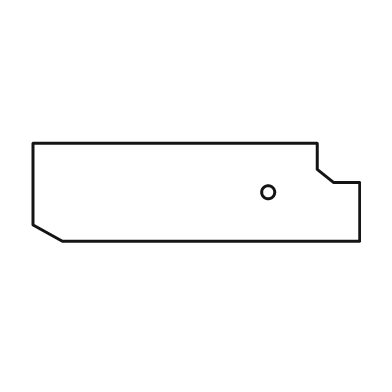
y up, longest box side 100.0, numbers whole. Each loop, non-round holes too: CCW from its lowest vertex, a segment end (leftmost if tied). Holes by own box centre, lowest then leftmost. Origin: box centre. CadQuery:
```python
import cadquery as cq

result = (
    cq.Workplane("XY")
    .moveTo(-41.0, -15.0)
    .lineTo(50.0, -15.0)
    .lineTo(50.0, 3.0)
    .lineTo(42.0, 3.0)
    .lineTo(37.0, 7.0)
    .lineTo(37.0, 15.0)
    .lineTo(-50.0, 15.0)
    .lineTo(-50.0, -10.0)
    .close()
    .moveTo(22.0, 0.0)
    .circle(2.0)
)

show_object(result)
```